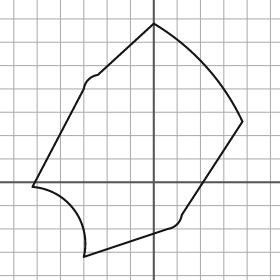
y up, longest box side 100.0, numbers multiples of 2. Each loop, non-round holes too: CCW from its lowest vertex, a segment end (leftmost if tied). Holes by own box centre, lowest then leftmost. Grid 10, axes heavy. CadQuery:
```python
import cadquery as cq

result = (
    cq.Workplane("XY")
    .moveTo(-30.0, -32.0)
    .lineTo(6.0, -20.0)
    .threePointArc((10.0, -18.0), (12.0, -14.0))
    .lineTo(38.0, 26.0)
    .threePointArc((22.0, 50.0), (0.0, 68.0))
    .lineTo(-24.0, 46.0)
    .threePointArc((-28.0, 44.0), (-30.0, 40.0))
    .lineTo(-52.0, -2.0)
    .threePointArc((-34.0, -12.0), (-30.0, -32.0))
    .close()
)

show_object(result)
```